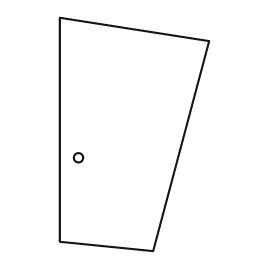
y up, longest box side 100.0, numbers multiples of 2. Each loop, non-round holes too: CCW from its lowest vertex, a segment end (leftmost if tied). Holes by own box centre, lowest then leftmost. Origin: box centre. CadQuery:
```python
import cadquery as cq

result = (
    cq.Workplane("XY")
    .moveTo(8.0, -50.0)
    .lineTo(32.0, 40.0)
    .lineTo(-32.0, 50.0)
    .lineTo(-32.0, -46.0)
    .close()
    .moveTo(-24.0, -10.0)
    .circle(2.0)
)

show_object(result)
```